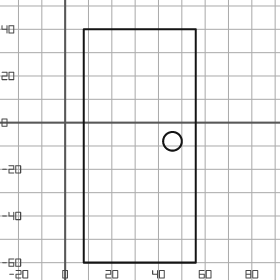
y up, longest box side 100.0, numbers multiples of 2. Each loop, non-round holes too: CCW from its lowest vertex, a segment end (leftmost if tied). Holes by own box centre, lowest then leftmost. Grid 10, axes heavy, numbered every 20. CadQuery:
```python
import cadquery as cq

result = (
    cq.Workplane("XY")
    .moveTo(8.0, -60.0)
    .lineTo(56.0, -60.0)
    .lineTo(56.0, 40.0)
    .lineTo(8.0, 40.0)
    .close()
    .moveTo(46.0, -8.0)
    .circle(4.0)
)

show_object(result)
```